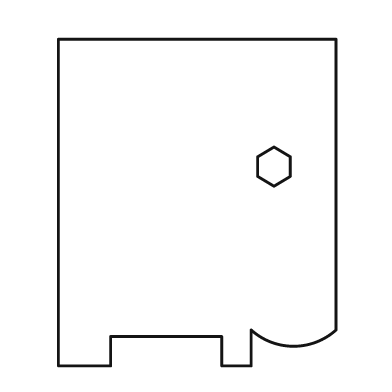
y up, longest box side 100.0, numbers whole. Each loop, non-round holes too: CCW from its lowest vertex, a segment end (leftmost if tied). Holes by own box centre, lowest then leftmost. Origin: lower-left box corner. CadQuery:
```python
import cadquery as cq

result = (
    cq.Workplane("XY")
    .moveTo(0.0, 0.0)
    .lineTo(16.0, 0.0)
    .lineTo(16.0, 9.0)
    .lineTo(50.0, 9.0)
    .lineTo(50.0, 0.0)
    .lineTo(59.0, 0.0)
    .lineTo(59.0, 11.0)
    .threePointArc((72.0, 6.0), (85.0, 11.0))
    .lineTo(85.0, 100.0)
    .lineTo(0.0, 100.0)
    .close()
    .moveTo(66.0, 55.0)
    .lineTo(71.0, 58.0)
    .lineTo(71.0, 64.0)
    .lineTo(66.0, 67.0)
    .lineTo(61.0, 64.0)
    .lineTo(61.0, 58.0)
    .close()
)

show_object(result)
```